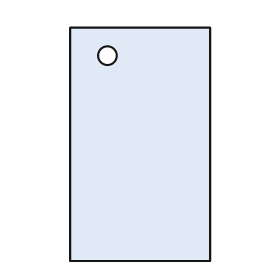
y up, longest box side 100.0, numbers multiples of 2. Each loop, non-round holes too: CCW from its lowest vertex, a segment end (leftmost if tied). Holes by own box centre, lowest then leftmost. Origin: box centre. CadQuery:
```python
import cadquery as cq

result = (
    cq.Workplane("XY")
    .moveTo(-30.0, -50.0)
    .lineTo(30.0, -50.0)
    .lineTo(30.0, 50.0)
    .lineTo(-30.0, 50.0)
    .close()
    .moveTo(-14.0, 38.0)
    .circle(4.0)
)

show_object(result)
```